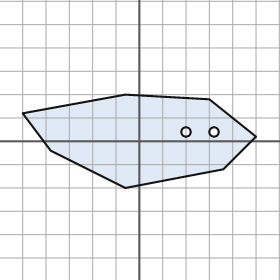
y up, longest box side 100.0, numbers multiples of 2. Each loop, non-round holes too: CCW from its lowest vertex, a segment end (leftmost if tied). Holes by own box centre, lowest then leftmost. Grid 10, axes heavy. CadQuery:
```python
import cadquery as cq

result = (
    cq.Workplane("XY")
    .moveTo(-6.0, -20.0)
    .lineTo(36.0, -12.0)
    .lineTo(50.0, 2.0)
    .lineTo(30.0, 18.0)
    .lineTo(-6.0, 20.0)
    .lineTo(-50.0, 12.0)
    .lineTo(-38.0, -4.0)
    .close()
    .moveTo(20.0, 4.0)
    .circle(2.0)
    .moveTo(32.0, 4.0)
    .circle(2.0)
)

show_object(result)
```